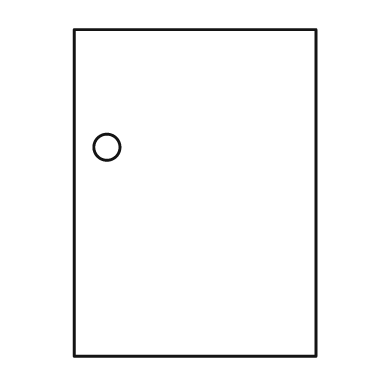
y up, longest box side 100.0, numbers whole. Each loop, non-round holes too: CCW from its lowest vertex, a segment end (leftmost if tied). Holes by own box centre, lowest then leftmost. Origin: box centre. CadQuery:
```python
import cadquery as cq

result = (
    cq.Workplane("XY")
    .moveTo(-37.0, -50.0)
    .lineTo(37.0, -50.0)
    .lineTo(37.0, 50.0)
    .lineTo(-37.0, 50.0)
    .close()
    .moveTo(-27.0, 14.0)
    .circle(4.0)
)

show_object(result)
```